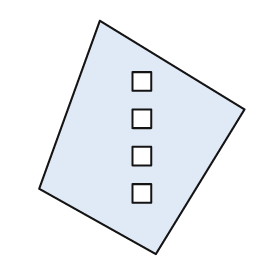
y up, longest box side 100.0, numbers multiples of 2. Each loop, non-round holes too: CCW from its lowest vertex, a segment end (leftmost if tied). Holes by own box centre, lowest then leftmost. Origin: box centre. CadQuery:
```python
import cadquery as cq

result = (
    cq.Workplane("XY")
    .moveTo(6.0, -50.0)
    .lineTo(44.0, 12.0)
    .lineTo(-18.0, 50.0)
    .lineTo(-44.0, -22.0)
    .close()
    .moveTo(-4.0, -28.0)
    .lineTo(4.0, -28.0)
    .lineTo(4.0, -20.0)
    .lineTo(-4.0, -20.0)
    .close()
    .moveTo(-4.0, -12.0)
    .lineTo(4.0, -12.0)
    .lineTo(4.0, -4.0)
    .lineTo(-4.0, -4.0)
    .close()
    .moveTo(-4.0, 4.0)
    .lineTo(4.0, 4.0)
    .lineTo(4.0, 12.0)
    .lineTo(-4.0, 12.0)
    .close()
    .moveTo(-4.0, 20.0)
    .lineTo(4.0, 20.0)
    .lineTo(4.0, 28.0)
    .lineTo(-4.0, 28.0)
    .close()
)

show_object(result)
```